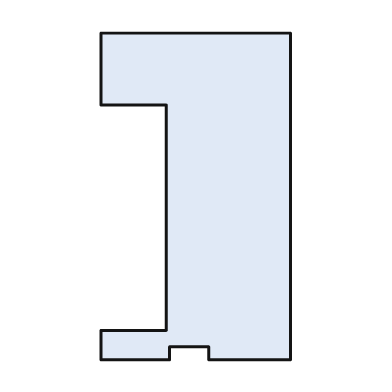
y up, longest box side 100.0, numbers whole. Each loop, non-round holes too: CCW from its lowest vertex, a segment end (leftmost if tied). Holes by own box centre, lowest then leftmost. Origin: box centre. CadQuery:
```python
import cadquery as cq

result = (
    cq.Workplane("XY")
    .moveTo(-29.0, -50.0)
    .lineTo(-8.0, -50.0)
    .lineTo(-8.0, -46.0)
    .lineTo(4.0, -46.0)
    .lineTo(4.0, -50.0)
    .lineTo(29.0, -50.0)
    .lineTo(29.0, 50.0)
    .lineTo(-29.0, 50.0)
    .lineTo(-29.0, 28.0)
    .lineTo(-9.0, 28.0)
    .lineTo(-9.0, -41.0)
    .lineTo(-29.0, -41.0)
    .close()
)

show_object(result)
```